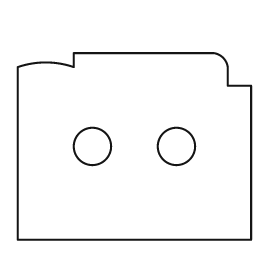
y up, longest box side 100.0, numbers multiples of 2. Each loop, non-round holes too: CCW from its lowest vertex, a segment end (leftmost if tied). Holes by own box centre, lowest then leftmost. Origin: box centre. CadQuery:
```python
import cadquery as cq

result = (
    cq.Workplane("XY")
    .moveTo(-50.0, -40.0)
    .lineTo(50.0, -40.0)
    .lineTo(50.0, 26.0)
    .lineTo(40.0, 26.0)
    .lineTo(40.0, 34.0)
    .threePointArc((38.0, 38.0), (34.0, 40.0))
    .lineTo(-26.0, 40.0)
    .lineTo(-26.0, 34.0)
    .threePointArc((-38.0, 36.0), (-50.0, 34.0))
    .close()
    .moveTo(-18.0, 0.0)
    .circle(8.0)
    .moveTo(18.0, 0.0)
    .circle(8.0)
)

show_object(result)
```